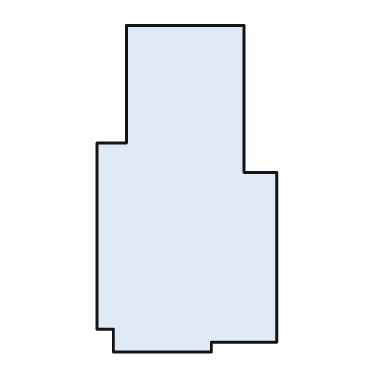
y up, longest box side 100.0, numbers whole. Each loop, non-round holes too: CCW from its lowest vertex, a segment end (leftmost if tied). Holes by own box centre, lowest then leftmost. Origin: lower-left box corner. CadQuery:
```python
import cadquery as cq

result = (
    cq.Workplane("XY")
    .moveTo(5.0, 0.0)
    .lineTo(35.0, 0.0)
    .lineTo(35.0, 3.0)
    .lineTo(55.0, 3.0)
    .lineTo(55.0, 55.0)
    .lineTo(45.0, 55.0)
    .lineTo(45.0, 100.0)
    .lineTo(9.0, 100.0)
    .lineTo(9.0, 64.0)
    .lineTo(0.0, 64.0)
    .lineTo(0.0, 7.0)
    .lineTo(5.0, 7.0)
    .close()
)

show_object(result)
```